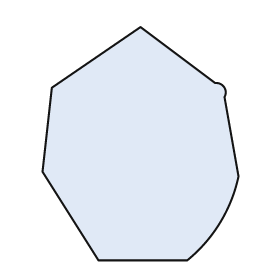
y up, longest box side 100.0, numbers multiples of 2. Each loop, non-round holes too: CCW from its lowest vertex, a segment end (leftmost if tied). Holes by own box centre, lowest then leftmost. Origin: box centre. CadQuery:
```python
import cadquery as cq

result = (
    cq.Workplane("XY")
    .moveTo(-18.0, -50.0)
    .lineTo(20.0, -50.0)
    .threePointArc((34.0, -34.0), (42.0, -14.0))
    .lineTo(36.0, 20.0)
    .threePointArc((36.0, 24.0), (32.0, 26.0))
    .lineTo(0.0, 50.0)
    .lineTo(-38.0, 24.0)
    .lineTo(-42.0, -12.0)
    .close()
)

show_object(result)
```